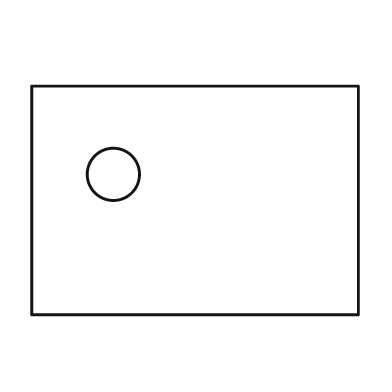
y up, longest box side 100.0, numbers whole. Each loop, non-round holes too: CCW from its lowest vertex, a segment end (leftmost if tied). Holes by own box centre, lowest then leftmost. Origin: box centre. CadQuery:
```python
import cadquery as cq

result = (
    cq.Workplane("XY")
    .moveTo(-50.0, -35.0)
    .lineTo(50.0, -35.0)
    .lineTo(50.0, 35.0)
    .lineTo(-50.0, 35.0)
    .close()
    .moveTo(-25.0, 8.0)
    .circle(8.0)
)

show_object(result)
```